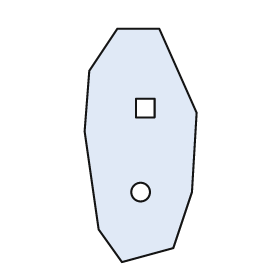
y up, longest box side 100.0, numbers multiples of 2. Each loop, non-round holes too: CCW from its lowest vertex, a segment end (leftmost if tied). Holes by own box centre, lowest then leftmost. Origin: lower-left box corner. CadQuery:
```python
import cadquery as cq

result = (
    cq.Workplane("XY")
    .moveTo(16.0, 0.0)
    .lineTo(38.0, 6.0)
    .lineTo(46.0, 30.0)
    .lineTo(48.0, 64.0)
    .lineTo(32.0, 100.0)
    .lineTo(14.0, 100.0)
    .lineTo(2.0, 82.0)
    .lineTo(0.0, 56.0)
    .lineTo(6.0, 14.0)
    .close()
    .moveTo(24.0, 30.0)
    .circle(4.0)
    .moveTo(22.0, 62.0)
    .lineTo(30.0, 62.0)
    .lineTo(30.0, 70.0)
    .lineTo(22.0, 70.0)
    .close()
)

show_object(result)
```